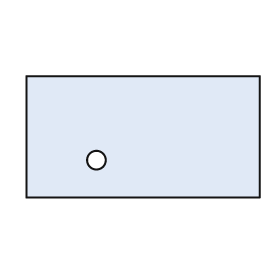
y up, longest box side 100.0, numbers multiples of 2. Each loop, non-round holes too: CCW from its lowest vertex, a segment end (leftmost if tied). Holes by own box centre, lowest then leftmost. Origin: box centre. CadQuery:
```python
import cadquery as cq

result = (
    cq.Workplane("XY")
    .moveTo(-50.0, -26.0)
    .lineTo(50.0, -26.0)
    .lineTo(50.0, 26.0)
    .lineTo(-50.0, 26.0)
    .close()
    .moveTo(-20.0, -10.0)
    .circle(4.0)
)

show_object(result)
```